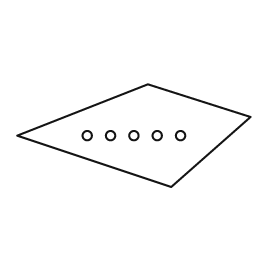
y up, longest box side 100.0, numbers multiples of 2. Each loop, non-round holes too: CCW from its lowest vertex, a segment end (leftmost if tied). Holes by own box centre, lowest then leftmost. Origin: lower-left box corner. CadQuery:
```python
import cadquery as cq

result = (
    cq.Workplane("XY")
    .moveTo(66.0, 0.0)
    .lineTo(100.0, 30.0)
    .lineTo(56.0, 44.0)
    .lineTo(0.0, 22.0)
    .close()
    .moveTo(30.0, 22.0)
    .circle(2.0)
    .moveTo(40.0, 22.0)
    .circle(2.0)
    .moveTo(50.0, 22.0)
    .circle(2.0)
    .moveTo(60.0, 22.0)
    .circle(2.0)
    .moveTo(70.0, 22.0)
    .circle(2.0)
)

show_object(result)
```